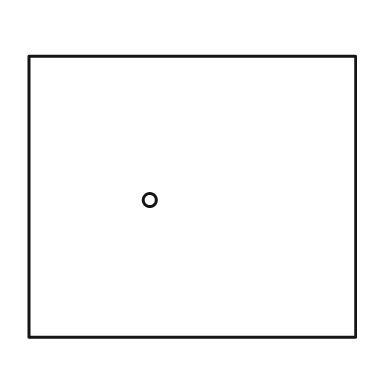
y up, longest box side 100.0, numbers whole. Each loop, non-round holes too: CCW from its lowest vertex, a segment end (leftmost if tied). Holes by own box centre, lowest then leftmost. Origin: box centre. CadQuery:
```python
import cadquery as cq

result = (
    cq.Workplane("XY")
    .moveTo(-50.0, -43.0)
    .lineTo(50.0, -43.0)
    .lineTo(50.0, 43.0)
    .lineTo(-50.0, 43.0)
    .close()
    .moveTo(-13.0, -1.0)
    .circle(2.0)
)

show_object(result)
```